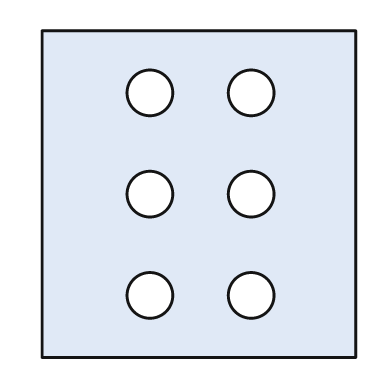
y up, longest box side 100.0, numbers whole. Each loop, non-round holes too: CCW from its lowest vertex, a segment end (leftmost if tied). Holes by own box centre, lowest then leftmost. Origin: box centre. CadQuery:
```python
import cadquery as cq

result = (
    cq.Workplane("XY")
    .moveTo(-48.0, -50.0)
    .lineTo(48.0, -50.0)
    .lineTo(48.0, 50.0)
    .lineTo(-48.0, 50.0)
    .close()
    .moveTo(-15.0, -31.0)
    .circle(7.0)
    .moveTo(16.0, -31.0)
    .circle(7.0)
    .moveTo(-15.0, 0.0)
    .circle(7.0)
    .moveTo(16.0, 0.0)
    .circle(7.0)
    .moveTo(-15.0, 31.0)
    .circle(7.0)
    .moveTo(16.0, 31.0)
    .circle(7.0)
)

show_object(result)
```